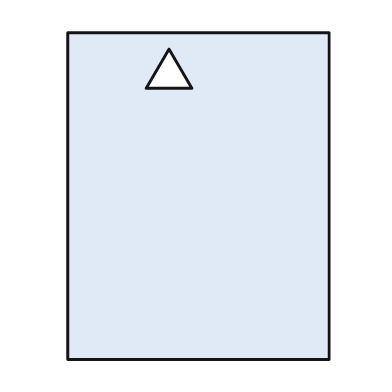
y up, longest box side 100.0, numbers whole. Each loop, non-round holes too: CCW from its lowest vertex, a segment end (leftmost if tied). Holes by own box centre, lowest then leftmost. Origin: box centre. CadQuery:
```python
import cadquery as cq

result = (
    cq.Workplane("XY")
    .moveTo(-40.0, -50.0)
    .lineTo(40.0, -50.0)
    .lineTo(40.0, 50.0)
    .lineTo(-40.0, 50.0)
    .close()
    .moveTo(-16.0, 33.0)
    .lineTo(-2.0, 33.0)
    .lineTo(-9.0, 45.0)
    .close()
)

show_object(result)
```